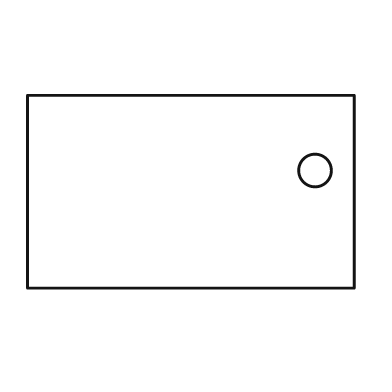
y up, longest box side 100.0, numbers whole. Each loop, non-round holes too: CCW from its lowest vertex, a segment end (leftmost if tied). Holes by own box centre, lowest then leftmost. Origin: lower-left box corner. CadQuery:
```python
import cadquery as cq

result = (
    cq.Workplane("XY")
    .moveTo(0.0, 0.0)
    .lineTo(100.0, 0.0)
    .lineTo(100.0, 59.0)
    .lineTo(0.0, 59.0)
    .close()
    .moveTo(88.0, 36.0)
    .circle(5.0)
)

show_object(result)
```